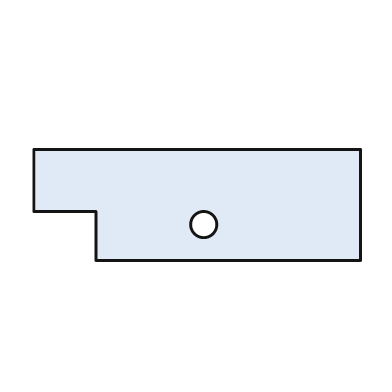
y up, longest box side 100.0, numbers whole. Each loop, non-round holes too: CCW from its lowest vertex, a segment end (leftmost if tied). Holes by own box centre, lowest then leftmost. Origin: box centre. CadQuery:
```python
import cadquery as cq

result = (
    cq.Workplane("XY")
    .moveTo(-31.0, -17.0)
    .lineTo(50.0, -17.0)
    .lineTo(50.0, 17.0)
    .lineTo(-50.0, 17.0)
    .lineTo(-50.0, -2.0)
    .lineTo(-31.0, -2.0)
    .close()
    .moveTo(2.0, -6.0)
    .circle(4.0)
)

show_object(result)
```